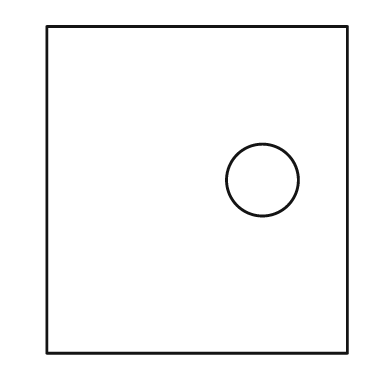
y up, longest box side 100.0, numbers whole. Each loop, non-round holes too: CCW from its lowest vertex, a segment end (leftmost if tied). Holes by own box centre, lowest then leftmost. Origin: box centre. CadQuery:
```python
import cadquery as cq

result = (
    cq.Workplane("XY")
    .moveTo(-46.0, -50.0)
    .lineTo(46.0, -50.0)
    .lineTo(46.0, 50.0)
    .lineTo(-46.0, 50.0)
    .close()
    .moveTo(20.0, 3.0)
    .circle(11.0)
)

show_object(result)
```